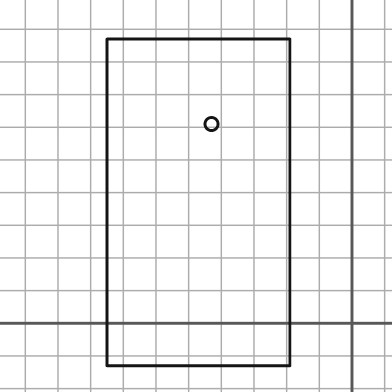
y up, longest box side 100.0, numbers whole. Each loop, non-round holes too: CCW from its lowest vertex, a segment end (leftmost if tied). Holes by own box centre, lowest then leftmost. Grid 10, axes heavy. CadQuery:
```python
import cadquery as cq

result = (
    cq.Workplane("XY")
    .moveTo(-75.0, -13.0)
    .lineTo(-19.0, -13.0)
    .lineTo(-19.0, 87.0)
    .lineTo(-75.0, 87.0)
    .close()
    .moveTo(-43.0, 61.0)
    .circle(2.0)
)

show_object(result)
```